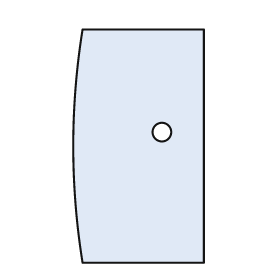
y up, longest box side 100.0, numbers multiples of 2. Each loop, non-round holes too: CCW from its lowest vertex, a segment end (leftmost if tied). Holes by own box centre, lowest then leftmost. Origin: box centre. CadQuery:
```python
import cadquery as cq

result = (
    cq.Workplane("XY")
    .moveTo(-24.0, -50.0)
    .lineTo(28.0, -50.0)
    .lineTo(28.0, 50.0)
    .lineTo(-24.0, 50.0)
    .threePointArc((-28.0, 0.0), (-24.0, -50.0))
    .close()
    .moveTo(10.0, 6.0)
    .circle(4.0)
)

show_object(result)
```